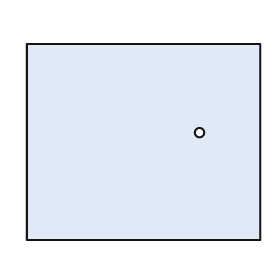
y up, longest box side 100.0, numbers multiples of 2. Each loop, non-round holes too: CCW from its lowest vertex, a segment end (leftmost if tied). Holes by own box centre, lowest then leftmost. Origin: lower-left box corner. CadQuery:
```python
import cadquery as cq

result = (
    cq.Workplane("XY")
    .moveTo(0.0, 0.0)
    .lineTo(100.0, 0.0)
    .lineTo(100.0, 84.0)
    .lineTo(0.0, 84.0)
    .close()
    .moveTo(74.0, 46.0)
    .circle(2.0)
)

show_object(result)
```